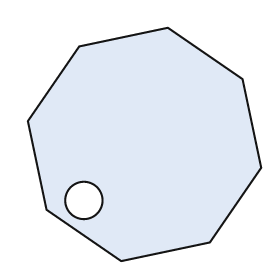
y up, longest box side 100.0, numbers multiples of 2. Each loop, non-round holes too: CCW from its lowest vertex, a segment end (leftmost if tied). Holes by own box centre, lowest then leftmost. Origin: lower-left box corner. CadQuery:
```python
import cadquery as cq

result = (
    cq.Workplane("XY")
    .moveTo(40.0, 0.0)
    .lineTo(78.0, 8.0)
    .lineTo(100.0, 40.0)
    .lineTo(92.0, 78.0)
    .lineTo(60.0, 100.0)
    .lineTo(22.0, 92.0)
    .lineTo(0.0, 60.0)
    .lineTo(8.0, 22.0)
    .close()
    .moveTo(24.0, 26.0)
    .circle(8.0)
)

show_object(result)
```